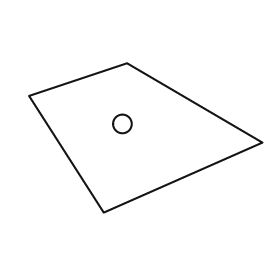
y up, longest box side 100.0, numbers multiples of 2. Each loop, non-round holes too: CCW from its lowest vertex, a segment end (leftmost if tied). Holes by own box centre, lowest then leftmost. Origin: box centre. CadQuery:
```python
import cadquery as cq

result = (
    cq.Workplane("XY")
    .moveTo(-18.0, -32.0)
    .lineTo(50.0, -2.0)
    .lineTo(-8.0, 32.0)
    .lineTo(-50.0, 18.0)
    .close()
    .moveTo(-10.0, 6.0)
    .circle(4.0)
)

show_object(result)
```